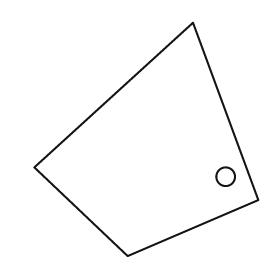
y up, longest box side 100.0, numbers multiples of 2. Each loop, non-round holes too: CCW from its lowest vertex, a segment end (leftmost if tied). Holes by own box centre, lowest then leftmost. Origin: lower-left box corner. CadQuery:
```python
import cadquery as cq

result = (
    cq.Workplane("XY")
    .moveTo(40.0, 0.0)
    .lineTo(96.0, 24.0)
    .lineTo(68.0, 100.0)
    .lineTo(0.0, 38.0)
    .close()
    .moveTo(82.0, 34.0)
    .circle(4.0)
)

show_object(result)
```